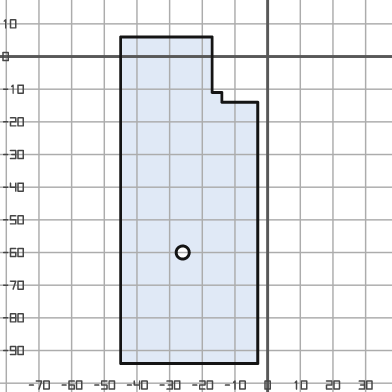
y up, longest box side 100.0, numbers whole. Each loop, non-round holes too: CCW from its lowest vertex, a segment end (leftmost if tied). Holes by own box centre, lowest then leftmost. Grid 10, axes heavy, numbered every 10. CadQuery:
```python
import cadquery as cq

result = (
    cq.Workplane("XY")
    .moveTo(-45.0, -94.0)
    .lineTo(-3.0, -94.0)
    .lineTo(-3.0, -14.0)
    .lineTo(-14.0, -14.0)
    .lineTo(-14.0, -11.0)
    .lineTo(-17.0, -11.0)
    .lineTo(-17.0, 6.0)
    .lineTo(-45.0, 6.0)
    .close()
    .moveTo(-26.0, -60.0)
    .circle(2.0)
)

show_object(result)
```